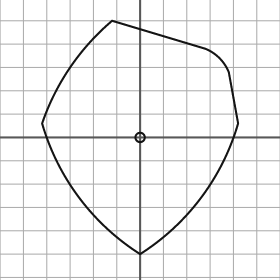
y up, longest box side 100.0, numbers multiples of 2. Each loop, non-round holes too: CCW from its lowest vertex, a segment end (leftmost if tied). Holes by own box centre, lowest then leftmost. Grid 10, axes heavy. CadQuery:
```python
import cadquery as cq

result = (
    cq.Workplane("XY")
    .moveTo(0.0, -50.0)
    .threePointArc((26.0, -26.0), (42.0, 6.0))
    .lineTo(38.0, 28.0)
    .threePointArc((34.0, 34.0), (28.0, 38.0))
    .lineTo(-12.0, 50.0)
    .threePointArc((-30.0, 30.0), (-42.0, 6.0))
    .threePointArc((-26.0, -26.0), (0.0, -50.0))
    .close()
    .moveTo(0.0, 0.0)
    .circle(2.0)
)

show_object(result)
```